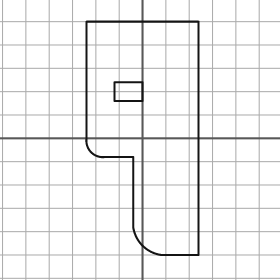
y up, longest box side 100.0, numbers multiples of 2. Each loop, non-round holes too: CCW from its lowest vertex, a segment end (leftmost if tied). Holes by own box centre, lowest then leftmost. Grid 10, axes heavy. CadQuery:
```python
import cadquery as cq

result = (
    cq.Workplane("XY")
    .moveTo(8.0, -50.0)
    .lineTo(24.0, -50.0)
    .lineTo(24.0, 50.0)
    .lineTo(-24.0, 50.0)
    .lineTo(-24.0, 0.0)
    .threePointArc((-22.0, -6.0), (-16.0, -8.0))
    .lineTo(-4.0, -8.0)
    .lineTo(-4.0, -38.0)
    .threePointArc((0.0, -46.0), (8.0, -50.0))
    .close()
    .moveTo(-12.0, 16.0)
    .lineTo(0.0, 16.0)
    .lineTo(0.0, 24.0)
    .lineTo(-12.0, 24.0)
    .close()
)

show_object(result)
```